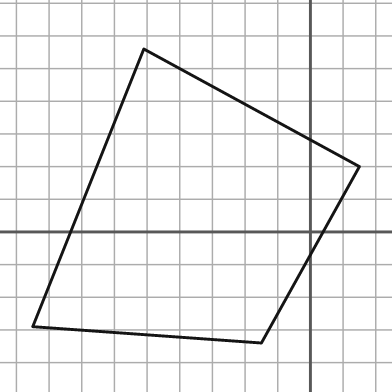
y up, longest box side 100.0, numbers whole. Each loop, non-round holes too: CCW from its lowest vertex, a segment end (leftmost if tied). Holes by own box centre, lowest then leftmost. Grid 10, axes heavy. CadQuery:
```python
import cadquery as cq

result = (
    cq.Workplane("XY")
    .moveTo(-15.0, -34.0)
    .lineTo(15.0, 20.0)
    .lineTo(-51.0, 56.0)
    .lineTo(-85.0, -29.0)
    .close()
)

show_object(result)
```